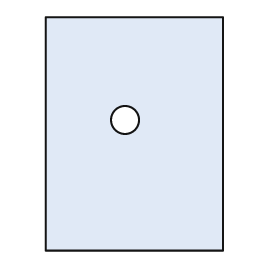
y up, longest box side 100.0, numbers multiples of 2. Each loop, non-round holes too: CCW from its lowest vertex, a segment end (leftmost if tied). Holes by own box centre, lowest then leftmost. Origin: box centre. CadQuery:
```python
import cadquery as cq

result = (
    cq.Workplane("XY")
    .moveTo(-38.0, -50.0)
    .lineTo(38.0, -50.0)
    .lineTo(38.0, 50.0)
    .lineTo(-38.0, 50.0)
    .close()
    .moveTo(-4.0, 6.0)
    .circle(6.0)
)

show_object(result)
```